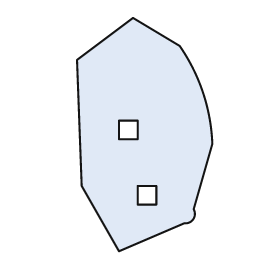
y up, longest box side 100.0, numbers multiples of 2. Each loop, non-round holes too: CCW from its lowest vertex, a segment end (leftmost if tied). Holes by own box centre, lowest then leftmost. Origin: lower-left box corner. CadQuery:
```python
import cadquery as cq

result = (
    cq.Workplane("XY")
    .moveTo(18.0, 0.0)
    .lineTo(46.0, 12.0)
    .threePointArc((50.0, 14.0), (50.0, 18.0))
    .lineTo(58.0, 46.0)
    .threePointArc((54.0, 68.0), (44.0, 88.0))
    .lineTo(24.0, 100.0)
    .lineTo(0.0, 82.0)
    .lineTo(2.0, 28.0)
    .close()
    .moveTo(26.0, 20.0)
    .lineTo(34.0, 20.0)
    .lineTo(34.0, 28.0)
    .lineTo(26.0, 28.0)
    .close()
    .moveTo(18.0, 48.0)
    .lineTo(26.0, 48.0)
    .lineTo(26.0, 56.0)
    .lineTo(18.0, 56.0)
    .close()
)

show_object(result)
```